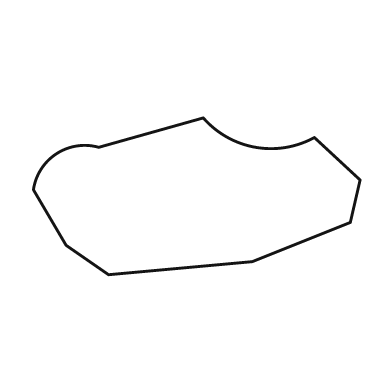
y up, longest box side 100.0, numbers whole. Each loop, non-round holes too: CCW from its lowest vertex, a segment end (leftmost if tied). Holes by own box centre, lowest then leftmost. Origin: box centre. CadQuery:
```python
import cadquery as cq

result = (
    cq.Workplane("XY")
    .moveTo(-27.0, -24.0)
    .lineTo(17.0, -20.0)
    .lineTo(47.0, -8.0)
    .lineTo(50.0, 5.0)
    .lineTo(36.0, 18.0)
    .threePointArc((18.0, 15.0), (2.0, 24.0))
    .lineTo(-30.0, 15.0)
    .threePointArc((-43.0, 13.0), (-50.0, 2.0))
    .lineTo(-40.0, -15.0)
    .close()
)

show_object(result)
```